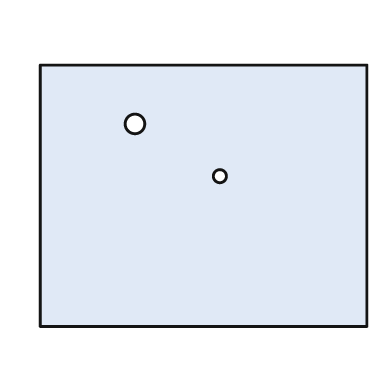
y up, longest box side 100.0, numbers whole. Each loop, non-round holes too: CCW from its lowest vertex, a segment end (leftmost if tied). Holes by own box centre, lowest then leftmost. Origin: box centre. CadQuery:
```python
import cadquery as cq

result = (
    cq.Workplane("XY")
    .moveTo(-50.0, -40.0)
    .lineTo(50.0, -40.0)
    .lineTo(50.0, 40.0)
    .lineTo(-50.0, 40.0)
    .close()
    .moveTo(5.0, 6.0)
    .circle(2.0)
    .moveTo(-21.0, 22.0)
    .circle(3.0)
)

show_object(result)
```